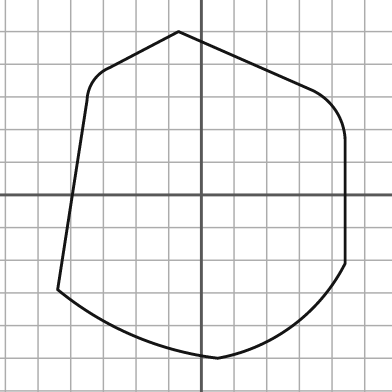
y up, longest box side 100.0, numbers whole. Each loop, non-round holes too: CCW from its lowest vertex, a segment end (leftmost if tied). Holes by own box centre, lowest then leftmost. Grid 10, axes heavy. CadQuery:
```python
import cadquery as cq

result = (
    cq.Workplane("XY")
    .moveTo(5.0, -50.0)
    .threePointArc((28.0, -40.0), (44.0, -21.0))
    .lineTo(44.0, 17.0)
    .threePointArc((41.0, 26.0), (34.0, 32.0))
    .lineTo(-7.0, 50.0)
    .lineTo(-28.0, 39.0)
    .threePointArc((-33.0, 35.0), (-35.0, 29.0))
    .lineTo(-44.0, -29.0)
    .threePointArc((-21.0, -43.0), (5.0, -50.0))
    .close()
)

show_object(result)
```